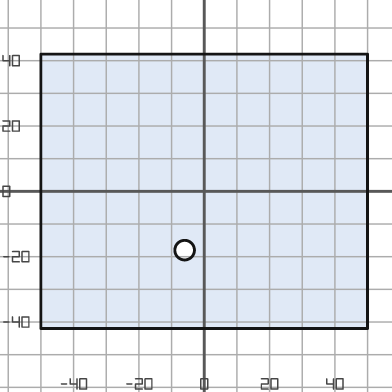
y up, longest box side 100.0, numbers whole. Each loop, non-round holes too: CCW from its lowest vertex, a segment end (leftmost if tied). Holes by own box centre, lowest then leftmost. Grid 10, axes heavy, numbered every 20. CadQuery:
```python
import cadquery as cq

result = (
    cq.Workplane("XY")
    .moveTo(-50.0, -42.0)
    .lineTo(50.0, -42.0)
    .lineTo(50.0, 42.0)
    .lineTo(-50.0, 42.0)
    .close()
    .moveTo(-6.0, -18.0)
    .circle(3.0)
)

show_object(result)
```